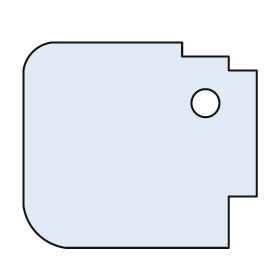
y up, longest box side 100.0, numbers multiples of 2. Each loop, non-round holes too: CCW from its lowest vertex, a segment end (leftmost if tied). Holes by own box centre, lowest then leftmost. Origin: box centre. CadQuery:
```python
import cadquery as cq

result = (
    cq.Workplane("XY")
    .moveTo(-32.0, -44.0)
    .lineTo(38.0, -44.0)
    .lineTo(38.0, -22.0)
    .lineTo(50.0, -22.0)
    .lineTo(50.0, 32.0)
    .lineTo(38.0, 32.0)
    .lineTo(38.0, 38.0)
    .lineTo(18.0, 38.0)
    .lineTo(18.0, 44.0)
    .lineTo(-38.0, 44.0)
    .threePointArc((-46.0, 40.0), (-50.0, 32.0))
    .lineTo(-50.0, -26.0)
    .threePointArc((-44.0, -38.0), (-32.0, -44.0))
    .close()
    .moveTo(28.0, 18.0)
    .circle(6.0)
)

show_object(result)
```